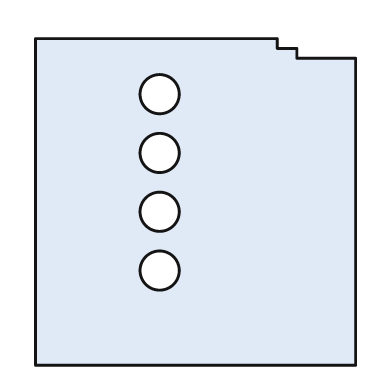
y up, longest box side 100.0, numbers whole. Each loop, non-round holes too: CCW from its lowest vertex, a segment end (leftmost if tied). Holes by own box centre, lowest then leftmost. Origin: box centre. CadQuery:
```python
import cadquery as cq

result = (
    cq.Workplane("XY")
    .moveTo(-49.0, -50.0)
    .lineTo(49.0, -50.0)
    .lineTo(49.0, 44.0)
    .lineTo(31.0, 44.0)
    .lineTo(31.0, 47.0)
    .lineTo(25.0, 47.0)
    .lineTo(25.0, 50.0)
    .lineTo(-49.0, 50.0)
    .close()
    .moveTo(-11.0, -21.0)
    .circle(6.0)
    .moveTo(-11.0, -3.0)
    .circle(6.0)
    .moveTo(-11.0, 15.0)
    .circle(6.0)
    .moveTo(-11.0, 33.0)
    .circle(6.0)
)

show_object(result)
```